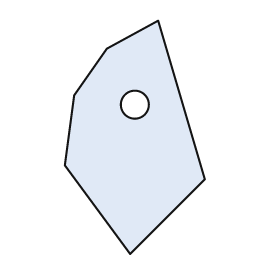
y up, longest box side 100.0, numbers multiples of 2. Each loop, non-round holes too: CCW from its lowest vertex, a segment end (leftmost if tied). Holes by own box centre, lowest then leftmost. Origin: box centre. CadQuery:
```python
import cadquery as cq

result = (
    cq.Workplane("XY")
    .moveTo(-2.0, -50.0)
    .lineTo(30.0, -18.0)
    .lineTo(10.0, 50.0)
    .lineTo(-12.0, 38.0)
    .lineTo(-26.0, 18.0)
    .lineTo(-30.0, -12.0)
    .close()
    .moveTo(0.0, 14.0)
    .circle(6.0)
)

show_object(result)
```